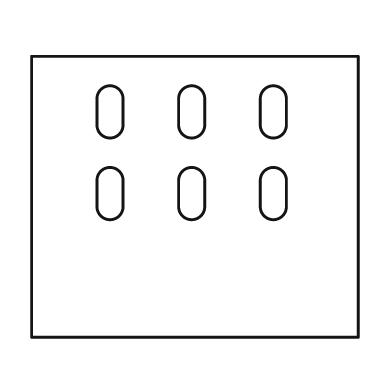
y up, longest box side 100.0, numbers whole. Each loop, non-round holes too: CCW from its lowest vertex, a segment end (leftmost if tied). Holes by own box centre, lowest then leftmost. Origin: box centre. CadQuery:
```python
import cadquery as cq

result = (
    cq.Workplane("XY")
    .moveTo(-50.0, -43.0)
    .lineTo(50.0, -43.0)
    .lineTo(50.0, 43.0)
    .lineTo(-50.0, 43.0)
    .close()
    .moveTo(-30.0, -3.0)
    .threePointArc((-26.0, -7.0), (-22.0, -3.0))
    .lineTo(-22.0, 5.0)
    .threePointArc((-26.0, 9.0), (-30.0, 5.0))
    .close()
    .moveTo(-5.0, -3.0)
    .threePointArc((-1.0, -7.0), (3.0, -3.0))
    .lineTo(3.0, 5.0)
    .threePointArc((-1.0, 9.0), (-5.0, 5.0))
    .close()
    .moveTo(20.0, -3.0)
    .threePointArc((24.0, -7.0), (28.0, -3.0))
    .lineTo(28.0, 5.0)
    .threePointArc((24.0, 9.0), (20.0, 5.0))
    .close()
    .moveTo(-30.0, 22.0)
    .threePointArc((-26.0, 18.0), (-22.0, 22.0))
    .lineTo(-22.0, 30.0)
    .threePointArc((-26.0, 34.0), (-30.0, 30.0))
    .close()
    .moveTo(-5.0, 22.0)
    .threePointArc((-1.0, 18.0), (3.0, 22.0))
    .lineTo(3.0, 30.0)
    .threePointArc((-1.0, 34.0), (-5.0, 30.0))
    .close()
    .moveTo(20.0, 22.0)
    .threePointArc((24.0, 18.0), (28.0, 22.0))
    .lineTo(28.0, 30.0)
    .threePointArc((24.0, 34.0), (20.0, 30.0))
    .close()
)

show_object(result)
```